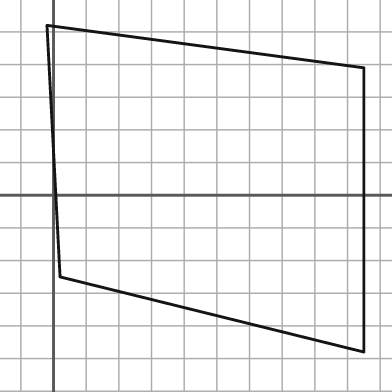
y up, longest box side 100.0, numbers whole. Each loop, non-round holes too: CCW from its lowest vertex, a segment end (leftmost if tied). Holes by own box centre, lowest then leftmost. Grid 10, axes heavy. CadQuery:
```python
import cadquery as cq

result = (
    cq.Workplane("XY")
    .moveTo(95.0, -48.0)
    .lineTo(95.0, 39.0)
    .lineTo(-2.0, 52.0)
    .lineTo(2.0, -25.0)
    .close()
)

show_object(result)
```